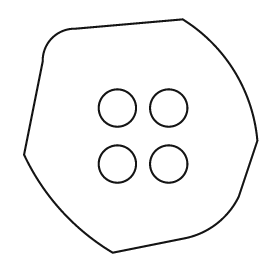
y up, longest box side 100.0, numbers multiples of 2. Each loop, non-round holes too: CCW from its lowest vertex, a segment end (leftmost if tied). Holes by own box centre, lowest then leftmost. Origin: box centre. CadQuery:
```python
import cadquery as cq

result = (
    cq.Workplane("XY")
    .moveTo(-12.0, -50.0)
    .lineTo(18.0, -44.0)
    .threePointArc((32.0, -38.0), (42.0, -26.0))
    .lineTo(50.0, -2.0)
    .threePointArc((40.0, 28.0), (18.0, 50.0))
    .lineTo(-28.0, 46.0)
    .threePointArc((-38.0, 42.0), (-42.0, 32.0))
    .lineTo(-50.0, -8.0)
    .threePointArc((-34.0, -32.0), (-12.0, -50.0))
    .close()
    .moveTo(-10.0, -12.0)
    .circle(8.0)
    .moveTo(12.0, -12.0)
    .circle(8.0)
    .moveTo(-10.0, 12.0)
    .circle(8.0)
    .moveTo(12.0, 12.0)
    .circle(8.0)
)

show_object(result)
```